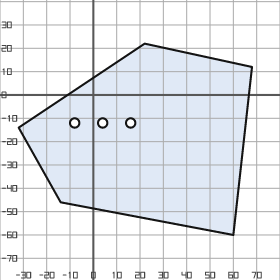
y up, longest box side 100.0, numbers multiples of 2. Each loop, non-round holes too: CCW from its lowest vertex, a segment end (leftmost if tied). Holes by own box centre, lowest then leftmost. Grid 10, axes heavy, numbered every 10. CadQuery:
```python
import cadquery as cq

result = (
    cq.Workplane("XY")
    .moveTo(60.0, -60.0)
    .lineTo(68.0, 12.0)
    .lineTo(22.0, 22.0)
    .lineTo(-32.0, -14.0)
    .lineTo(-14.0, -46.0)
    .close()
    .moveTo(-8.0, -12.0)
    .circle(2.0)
    .moveTo(4.0, -12.0)
    .circle(2.0)
    .moveTo(16.0, -12.0)
    .circle(2.0)
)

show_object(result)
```